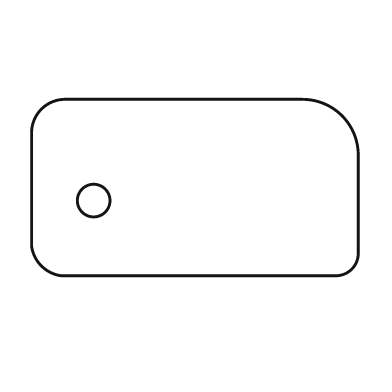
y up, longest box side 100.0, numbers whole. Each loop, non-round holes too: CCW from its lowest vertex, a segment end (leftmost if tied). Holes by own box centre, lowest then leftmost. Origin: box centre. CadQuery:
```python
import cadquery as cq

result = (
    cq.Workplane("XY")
    .moveTo(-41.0, -27.0)
    .lineTo(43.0, -27.0)
    .threePointArc((48.0, -25.0), (50.0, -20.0))
    .lineTo(50.0, 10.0)
    .threePointArc((45.0, 22.0), (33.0, 27.0))
    .lineTo(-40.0, 27.0)
    .threePointArc((-47.0, 24.0), (-50.0, 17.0))
    .lineTo(-50.0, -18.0)
    .threePointArc((-47.0, -24.0), (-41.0, -27.0))
    .close()
    .moveTo(-31.0, -4.0)
    .circle(5.0)
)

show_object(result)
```